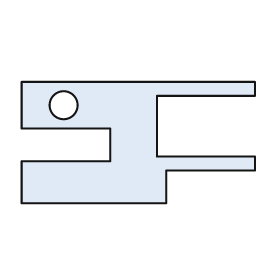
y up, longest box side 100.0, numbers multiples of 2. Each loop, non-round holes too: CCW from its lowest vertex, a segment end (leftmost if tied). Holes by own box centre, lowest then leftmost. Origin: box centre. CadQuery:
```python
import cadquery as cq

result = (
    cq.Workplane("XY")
    .moveTo(-50.0, -26.0)
    .lineTo(12.0, -26.0)
    .lineTo(12.0, -12.0)
    .lineTo(50.0, -12.0)
    .lineTo(50.0, -6.0)
    .lineTo(8.0, -6.0)
    .lineTo(8.0, 20.0)
    .lineTo(50.0, 20.0)
    .lineTo(50.0, 26.0)
    .lineTo(-50.0, 26.0)
    .lineTo(-50.0, 6.0)
    .lineTo(-12.0, 6.0)
    .lineTo(-12.0, -8.0)
    .lineTo(-50.0, -8.0)
    .close()
    .moveTo(-32.0, 16.0)
    .circle(6.0)
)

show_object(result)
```